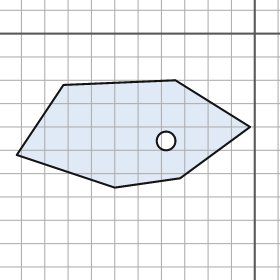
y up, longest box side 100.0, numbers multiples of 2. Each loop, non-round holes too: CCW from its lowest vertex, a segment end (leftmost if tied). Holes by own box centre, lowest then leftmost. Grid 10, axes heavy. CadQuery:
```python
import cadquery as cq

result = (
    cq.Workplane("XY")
    .moveTo(-60.0, -66.0)
    .lineTo(-32.0, -62.0)
    .lineTo(-2.0, -40.0)
    .lineTo(-34.0, -20.0)
    .lineTo(-82.0, -22.0)
    .lineTo(-102.0, -52.0)
    .close()
    .moveTo(-38.0, -46.0)
    .circle(4.0)
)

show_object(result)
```